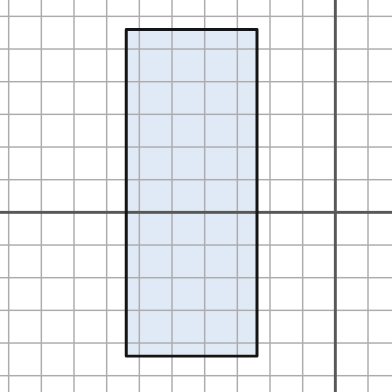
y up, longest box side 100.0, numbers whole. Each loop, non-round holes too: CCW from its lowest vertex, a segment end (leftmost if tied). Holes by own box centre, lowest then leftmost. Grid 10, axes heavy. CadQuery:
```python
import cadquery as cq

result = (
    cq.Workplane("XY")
    .moveTo(-64.0, -44.0)
    .lineTo(-24.0, -44.0)
    .lineTo(-24.0, 56.0)
    .lineTo(-64.0, 56.0)
    .close()
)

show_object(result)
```